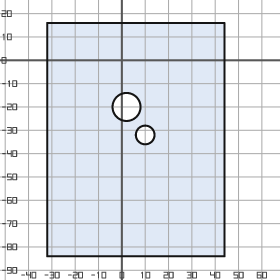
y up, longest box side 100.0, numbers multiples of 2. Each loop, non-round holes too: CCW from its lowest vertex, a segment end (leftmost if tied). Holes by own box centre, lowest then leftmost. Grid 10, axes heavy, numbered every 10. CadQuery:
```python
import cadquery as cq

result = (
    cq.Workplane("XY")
    .moveTo(-32.0, -84.0)
    .lineTo(44.0, -84.0)
    .lineTo(44.0, 16.0)
    .lineTo(-32.0, 16.0)
    .close()
    .moveTo(10.0, -32.0)
    .circle(4.0)
    .moveTo(2.0, -20.0)
    .circle(6.0)
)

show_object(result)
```